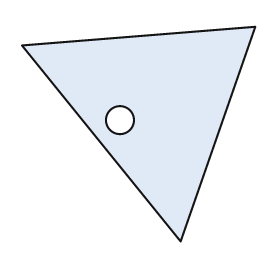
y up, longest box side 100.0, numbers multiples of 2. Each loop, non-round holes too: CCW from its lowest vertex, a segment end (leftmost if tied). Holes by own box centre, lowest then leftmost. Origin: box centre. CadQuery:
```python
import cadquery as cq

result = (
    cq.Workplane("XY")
    .moveTo(18.0, -46.0)
    .lineTo(50.0, 46.0)
    .lineTo(-50.0, 38.0)
    .close()
    .moveTo(-8.0, 6.0)
    .circle(6.0)
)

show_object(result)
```